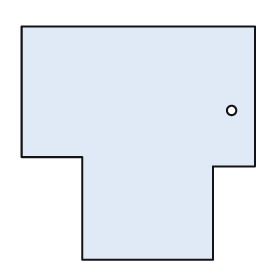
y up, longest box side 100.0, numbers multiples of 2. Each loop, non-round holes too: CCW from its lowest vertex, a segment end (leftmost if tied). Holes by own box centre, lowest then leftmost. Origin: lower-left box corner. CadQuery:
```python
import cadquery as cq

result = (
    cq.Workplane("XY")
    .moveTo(26.0, 0.0)
    .lineTo(82.0, 0.0)
    .lineTo(82.0, 40.0)
    .lineTo(100.0, 40.0)
    .lineTo(100.0, 100.0)
    .lineTo(0.0, 100.0)
    .lineTo(0.0, 44.0)
    .lineTo(26.0, 44.0)
    .close()
    .moveTo(90.0, 64.0)
    .circle(2.0)
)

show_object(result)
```